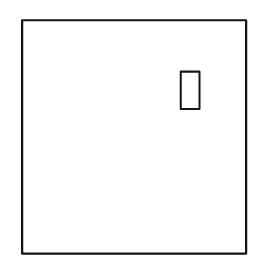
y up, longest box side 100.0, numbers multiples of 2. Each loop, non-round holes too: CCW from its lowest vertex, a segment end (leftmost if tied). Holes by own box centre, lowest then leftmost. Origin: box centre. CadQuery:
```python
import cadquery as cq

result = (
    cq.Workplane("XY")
    .moveTo(-48.0, -50.0)
    .lineTo(48.0, -50.0)
    .lineTo(48.0, 50.0)
    .lineTo(-48.0, 50.0)
    .close()
    .moveTo(20.0, 12.0)
    .lineTo(28.0, 12.0)
    .lineTo(28.0, 28.0)
    .lineTo(20.0, 28.0)
    .close()
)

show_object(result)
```